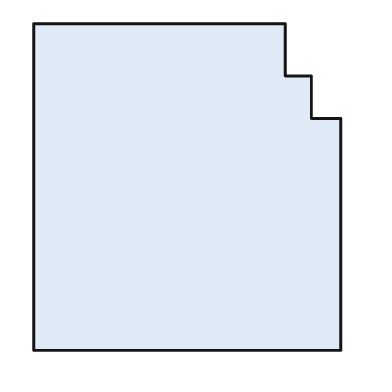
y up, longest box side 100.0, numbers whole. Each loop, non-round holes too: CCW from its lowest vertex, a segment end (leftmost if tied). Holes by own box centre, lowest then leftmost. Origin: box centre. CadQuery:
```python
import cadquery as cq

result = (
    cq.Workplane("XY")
    .moveTo(-47.0, -50.0)
    .lineTo(47.0, -50.0)
    .lineTo(47.0, 21.0)
    .lineTo(38.0, 21.0)
    .lineTo(38.0, 34.0)
    .lineTo(30.0, 34.0)
    .lineTo(30.0, 50.0)
    .lineTo(-47.0, 50.0)
    .close()
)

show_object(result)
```